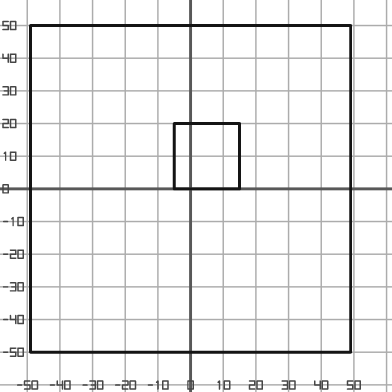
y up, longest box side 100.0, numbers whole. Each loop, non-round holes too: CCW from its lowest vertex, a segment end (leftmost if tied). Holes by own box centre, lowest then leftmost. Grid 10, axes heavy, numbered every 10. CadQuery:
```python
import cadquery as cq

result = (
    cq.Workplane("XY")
    .moveTo(-49.0, -50.0)
    .lineTo(49.0, -50.0)
    .lineTo(49.0, 50.0)
    .lineTo(-49.0, 50.0)
    .close()
    .moveTo(-5.0, 0.0)
    .lineTo(15.0, 0.0)
    .lineTo(15.0, 20.0)
    .lineTo(-5.0, 20.0)
    .close()
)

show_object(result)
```